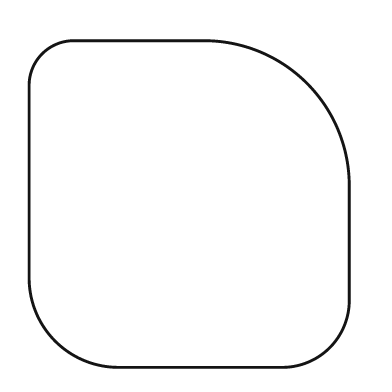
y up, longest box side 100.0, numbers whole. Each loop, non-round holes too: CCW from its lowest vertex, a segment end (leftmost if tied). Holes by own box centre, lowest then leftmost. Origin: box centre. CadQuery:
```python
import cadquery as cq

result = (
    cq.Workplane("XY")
    .moveTo(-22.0, -50.0)
    .lineTo(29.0, -50.0)
    .threePointArc((43.0, -44.0), (49.0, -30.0))
    .lineTo(49.0, 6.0)
    .threePointArc((36.0, 37.0), (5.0, 50.0))
    .lineTo(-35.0, 50.0)
    .threePointArc((-45.0, 46.0), (-49.0, 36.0))
    .lineTo(-49.0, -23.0)
    .threePointArc((-41.0, -42.0), (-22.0, -50.0))
    .close()
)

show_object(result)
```